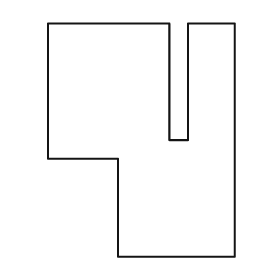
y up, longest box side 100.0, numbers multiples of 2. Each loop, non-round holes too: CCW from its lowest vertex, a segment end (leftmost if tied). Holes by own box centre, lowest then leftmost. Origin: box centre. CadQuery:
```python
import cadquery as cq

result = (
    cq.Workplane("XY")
    .moveTo(-10.0, -50.0)
    .lineTo(40.0, -50.0)
    .lineTo(40.0, 50.0)
    .lineTo(20.0, 50.0)
    .lineTo(20.0, 0.0)
    .lineTo(12.0, 0.0)
    .lineTo(12.0, 50.0)
    .lineTo(-40.0, 50.0)
    .lineTo(-40.0, -8.0)
    .lineTo(-10.0, -8.0)
    .close()
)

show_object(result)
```